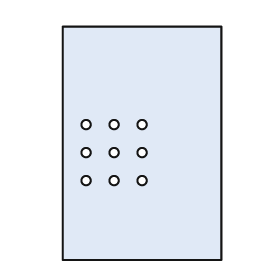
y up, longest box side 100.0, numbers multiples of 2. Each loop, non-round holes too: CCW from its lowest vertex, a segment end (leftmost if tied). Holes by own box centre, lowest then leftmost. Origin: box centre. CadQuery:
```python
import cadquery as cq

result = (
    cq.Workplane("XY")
    .moveTo(-34.0, -50.0)
    .lineTo(34.0, -50.0)
    .lineTo(34.0, 50.0)
    .lineTo(-34.0, 50.0)
    .close()
    .moveTo(-24.0, -16.0)
    .circle(2.0)
    .moveTo(-12.0, -16.0)
    .circle(2.0)
    .moveTo(0.0, -16.0)
    .circle(2.0)
    .moveTo(-24.0, -4.0)
    .circle(2.0)
    .moveTo(-12.0, -4.0)
    .circle(2.0)
    .moveTo(0.0, -4.0)
    .circle(2.0)
    .moveTo(-24.0, 8.0)
    .circle(2.0)
    .moveTo(-12.0, 8.0)
    .circle(2.0)
    .moveTo(0.0, 8.0)
    .circle(2.0)
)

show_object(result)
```